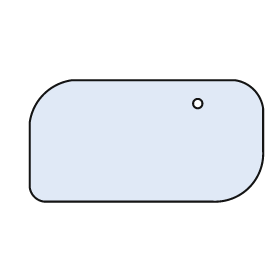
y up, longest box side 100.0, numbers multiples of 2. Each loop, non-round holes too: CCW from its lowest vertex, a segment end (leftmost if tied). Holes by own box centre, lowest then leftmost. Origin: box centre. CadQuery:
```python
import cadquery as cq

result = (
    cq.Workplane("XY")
    .moveTo(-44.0, -26.0)
    .lineTo(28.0, -26.0)
    .threePointArc((44.0, -20.0), (50.0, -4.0))
    .lineTo(50.0, 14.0)
    .threePointArc((46.0, 22.0), (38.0, 26.0))
    .lineTo(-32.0, 26.0)
    .threePointArc((-44.0, 20.0), (-50.0, 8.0))
    .lineTo(-50.0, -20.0)
    .threePointArc((-48.0, -24.0), (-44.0, -26.0))
    .close()
    .moveTo(22.0, 16.0)
    .circle(2.0)
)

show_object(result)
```